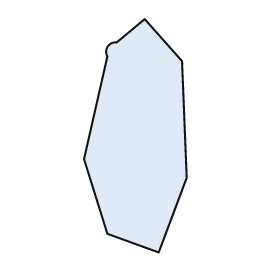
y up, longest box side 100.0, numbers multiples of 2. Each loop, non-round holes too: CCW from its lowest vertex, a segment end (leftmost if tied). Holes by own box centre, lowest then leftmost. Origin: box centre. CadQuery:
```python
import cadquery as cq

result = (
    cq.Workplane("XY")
    .moveTo(10.0, -50.0)
    .lineTo(22.0, -18.0)
    .lineTo(20.0, 32.0)
    .lineTo(4.0, 50.0)
    .lineTo(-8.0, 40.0)
    .threePointArc((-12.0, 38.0), (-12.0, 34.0))
    .lineTo(-22.0, -10.0)
    .lineTo(-12.0, -42.0)
    .close()
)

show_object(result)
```